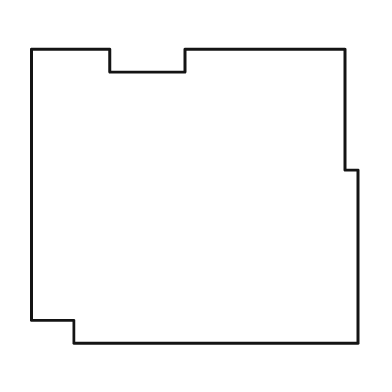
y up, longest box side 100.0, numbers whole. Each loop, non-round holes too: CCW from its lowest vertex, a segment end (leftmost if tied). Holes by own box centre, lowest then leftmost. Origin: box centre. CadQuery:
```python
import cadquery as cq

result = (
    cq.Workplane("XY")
    .moveTo(-37.0, -45.0)
    .lineTo(50.0, -45.0)
    .lineTo(50.0, 8.0)
    .lineTo(46.0, 8.0)
    .lineTo(46.0, 45.0)
    .lineTo(-3.0, 45.0)
    .lineTo(-3.0, 38.0)
    .lineTo(-26.0, 38.0)
    .lineTo(-26.0, 45.0)
    .lineTo(-50.0, 45.0)
    .lineTo(-50.0, -38.0)
    .lineTo(-37.0, -38.0)
    .close()
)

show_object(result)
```